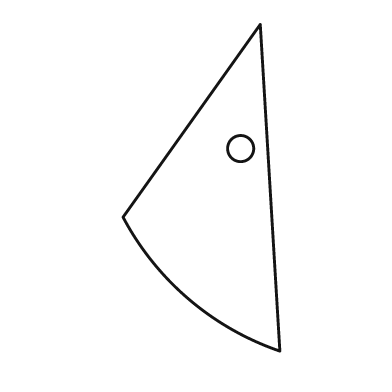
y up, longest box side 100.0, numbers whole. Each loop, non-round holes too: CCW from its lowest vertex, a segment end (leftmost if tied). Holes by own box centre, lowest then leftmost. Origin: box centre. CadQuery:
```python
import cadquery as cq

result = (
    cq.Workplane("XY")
    .moveTo(24.0, -50.0)
    .lineTo(18.0, 50.0)
    .lineTo(-24.0, -9.0)
    .threePointArc((-4.0, -34.0), (24.0, -50.0))
    .close()
    .moveTo(12.0, 12.0)
    .circle(4.0)
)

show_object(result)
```